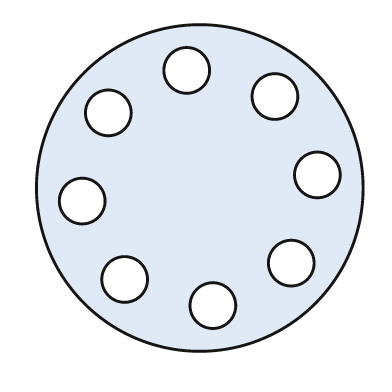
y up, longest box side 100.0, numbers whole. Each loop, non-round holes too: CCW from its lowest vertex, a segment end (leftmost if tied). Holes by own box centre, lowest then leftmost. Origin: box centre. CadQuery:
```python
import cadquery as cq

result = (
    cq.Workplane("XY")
    .moveTo(0.0, 0.0)
    .circle(50.0)
    .moveTo(4.0, -36.0)
    .circle(7.0)
    .moveTo(-23.0, -28.0)
    .circle(7.0)
    .moveTo(28.0, -23.0)
    .circle(7.0)
    .moveTo(-36.0, -4.0)
    .circle(7.0)
    .moveTo(36.0, 4.0)
    .circle(7.0)
    .moveTo(-28.0, 23.0)
    .circle(7.0)
    .moveTo(23.0, 28.0)
    .circle(7.0)
    .moveTo(-4.0, 36.0)
    .circle(7.0)
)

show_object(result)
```